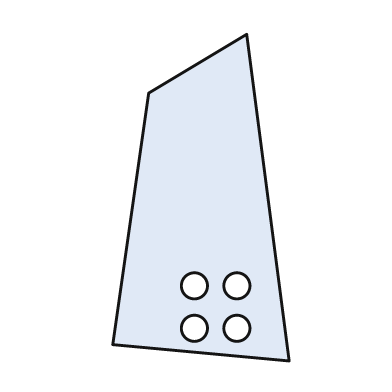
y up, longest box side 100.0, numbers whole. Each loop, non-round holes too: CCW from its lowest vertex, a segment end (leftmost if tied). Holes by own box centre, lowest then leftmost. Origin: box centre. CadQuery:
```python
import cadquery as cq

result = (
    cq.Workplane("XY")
    .moveTo(27.0, -50.0)
    .lineTo(14.0, 50.0)
    .lineTo(-16.0, 32.0)
    .lineTo(-27.0, -45.0)
    .close()
    .moveTo(-2.0, -40.0)
    .circle(4.0)
    .moveTo(11.0, -40.0)
    .circle(4.0)
    .moveTo(-2.0, -27.0)
    .circle(4.0)
    .moveTo(11.0, -27.0)
    .circle(4.0)
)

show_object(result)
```